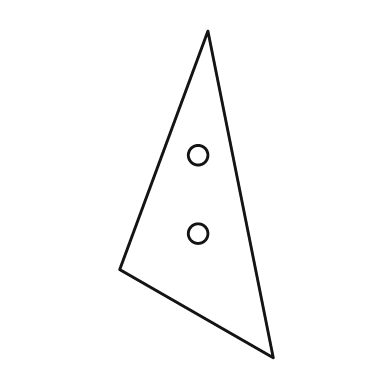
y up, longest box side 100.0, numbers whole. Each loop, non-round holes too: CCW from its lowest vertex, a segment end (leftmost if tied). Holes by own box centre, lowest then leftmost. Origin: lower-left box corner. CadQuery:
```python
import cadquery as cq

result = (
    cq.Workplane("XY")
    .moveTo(47.0, 0.0)
    .lineTo(27.0, 100.0)
    .lineTo(0.0, 27.0)
    .close()
    .moveTo(24.0, 38.0)
    .circle(3.0)
    .moveTo(24.0, 62.0)
    .circle(3.0)
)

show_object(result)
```